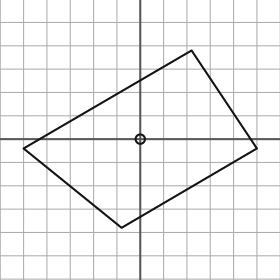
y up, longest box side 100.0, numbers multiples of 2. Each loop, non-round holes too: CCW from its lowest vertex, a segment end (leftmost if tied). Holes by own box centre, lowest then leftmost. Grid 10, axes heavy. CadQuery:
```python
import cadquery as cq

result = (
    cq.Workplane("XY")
    .moveTo(-8.0, -38.0)
    .lineTo(50.0, -4.0)
    .lineTo(22.0, 38.0)
    .lineTo(-50.0, -4.0)
    .close()
    .moveTo(0.0, 0.0)
    .circle(2.0)
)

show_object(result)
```